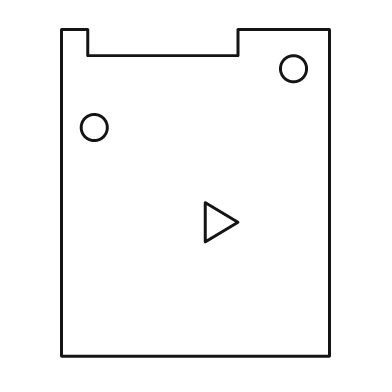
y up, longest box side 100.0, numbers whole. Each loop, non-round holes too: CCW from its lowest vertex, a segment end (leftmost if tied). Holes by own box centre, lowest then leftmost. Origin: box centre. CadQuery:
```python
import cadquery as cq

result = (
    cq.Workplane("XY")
    .moveTo(-41.0, -50.0)
    .lineTo(41.0, -50.0)
    .lineTo(41.0, 50.0)
    .lineTo(13.0, 50.0)
    .lineTo(13.0, 42.0)
    .lineTo(-33.0, 42.0)
    .lineTo(-33.0, 50.0)
    .lineTo(-41.0, 50.0)
    .close()
    .moveTo(3.0, -15.0)
    .lineTo(13.0, -9.0)
    .lineTo(3.0, -3.0)
    .close()
    .moveTo(-31.0, 20.0)
    .circle(4.0)
    .moveTo(30.0, 38.0)
    .circle(4.0)
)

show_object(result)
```